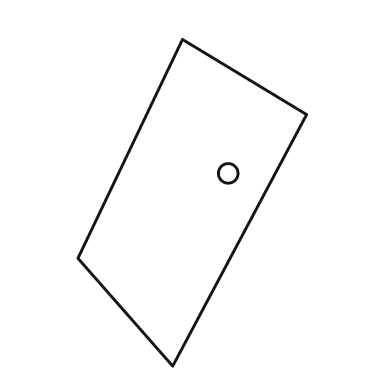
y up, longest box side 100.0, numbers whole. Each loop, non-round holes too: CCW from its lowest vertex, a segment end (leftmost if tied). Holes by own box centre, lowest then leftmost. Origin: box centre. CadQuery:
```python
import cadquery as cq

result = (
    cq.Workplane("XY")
    .moveTo(-6.0, -50.0)
    .lineTo(35.0, 27.0)
    .lineTo(-3.0, 50.0)
    .lineTo(-35.0, -17.0)
    .close()
    .moveTo(11.0, 9.0)
    .circle(3.0)
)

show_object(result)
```